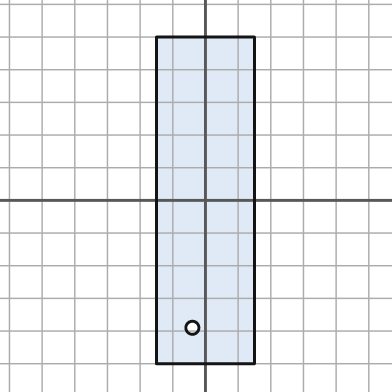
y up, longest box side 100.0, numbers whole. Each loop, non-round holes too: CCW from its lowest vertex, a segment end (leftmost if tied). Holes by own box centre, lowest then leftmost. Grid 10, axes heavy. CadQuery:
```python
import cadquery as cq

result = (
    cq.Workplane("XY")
    .moveTo(-15.0, -50.0)
    .lineTo(15.0, -50.0)
    .lineTo(15.0, 50.0)
    .lineTo(-15.0, 50.0)
    .close()
    .moveTo(-4.0, -39.0)
    .circle(2.0)
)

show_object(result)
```